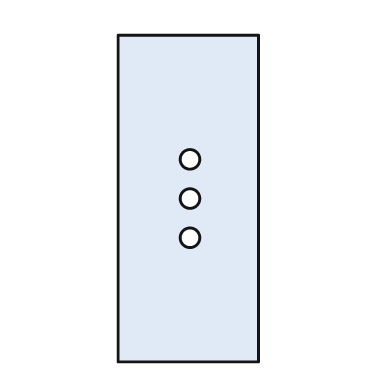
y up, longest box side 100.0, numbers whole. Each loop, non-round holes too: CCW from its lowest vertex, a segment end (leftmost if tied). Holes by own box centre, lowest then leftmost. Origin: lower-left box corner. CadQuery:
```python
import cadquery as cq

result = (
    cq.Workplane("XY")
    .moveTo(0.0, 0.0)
    .lineTo(43.0, 0.0)
    .lineTo(43.0, 100.0)
    .lineTo(0.0, 100.0)
    .close()
    .moveTo(22.0, 38.0)
    .circle(3.0)
    .moveTo(22.0, 50.0)
    .circle(3.0)
    .moveTo(22.0, 62.0)
    .circle(3.0)
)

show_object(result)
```